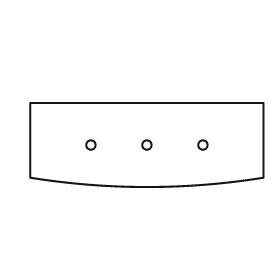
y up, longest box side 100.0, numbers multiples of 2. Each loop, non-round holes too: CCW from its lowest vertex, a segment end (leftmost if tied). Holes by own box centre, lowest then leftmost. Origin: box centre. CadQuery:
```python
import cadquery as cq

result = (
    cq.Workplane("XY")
    .moveTo(-50.0, -14.0)
    .threePointArc((0.0, -18.0), (50.0, -14.0))
    .lineTo(50.0, 18.0)
    .lineTo(-50.0, 18.0)
    .close()
    .moveTo(-24.0, 0.0)
    .circle(2.0)
    .moveTo(0.0, 0.0)
    .circle(2.0)
    .moveTo(24.0, 0.0)
    .circle(2.0)
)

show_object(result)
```